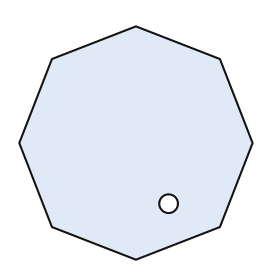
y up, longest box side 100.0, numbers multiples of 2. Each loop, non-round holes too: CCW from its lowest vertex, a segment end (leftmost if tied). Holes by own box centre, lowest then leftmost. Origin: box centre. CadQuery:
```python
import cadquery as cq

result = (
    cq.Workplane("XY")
    .moveTo(0.0, -50.0)
    .lineTo(36.0, -36.0)
    .lineTo(50.0, 0.0)
    .lineTo(36.0, 36.0)
    .lineTo(0.0, 50.0)
    .lineTo(-36.0, 36.0)
    .lineTo(-50.0, 0.0)
    .lineTo(-36.0, -36.0)
    .close()
    .moveTo(14.0, -26.0)
    .circle(4.0)
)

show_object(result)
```